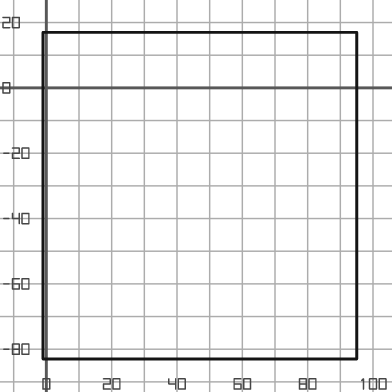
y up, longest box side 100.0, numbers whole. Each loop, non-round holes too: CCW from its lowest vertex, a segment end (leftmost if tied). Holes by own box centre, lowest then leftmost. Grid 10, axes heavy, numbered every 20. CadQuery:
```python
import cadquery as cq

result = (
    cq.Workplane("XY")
    .moveTo(-1.0, -83.0)
    .lineTo(95.0, -83.0)
    .lineTo(95.0, 17.0)
    .lineTo(-1.0, 17.0)
    .close()
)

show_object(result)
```